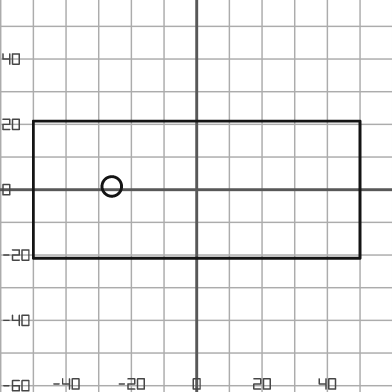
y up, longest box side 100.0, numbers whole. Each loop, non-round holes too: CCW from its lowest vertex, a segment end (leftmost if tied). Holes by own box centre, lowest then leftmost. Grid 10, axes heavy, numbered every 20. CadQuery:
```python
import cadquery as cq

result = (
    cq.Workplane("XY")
    .moveTo(-50.0, -21.0)
    .lineTo(50.0, -21.0)
    .lineTo(50.0, 21.0)
    .lineTo(-50.0, 21.0)
    .close()
    .moveTo(-26.0, 1.0)
    .circle(3.0)
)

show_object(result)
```